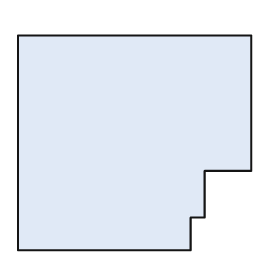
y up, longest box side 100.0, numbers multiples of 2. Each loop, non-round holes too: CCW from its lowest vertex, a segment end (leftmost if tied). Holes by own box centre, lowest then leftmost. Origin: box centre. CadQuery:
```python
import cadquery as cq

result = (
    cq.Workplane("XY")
    .moveTo(-50.0, -46.0)
    .lineTo(24.0, -46.0)
    .lineTo(24.0, -32.0)
    .lineTo(30.0, -32.0)
    .lineTo(30.0, -12.0)
    .lineTo(50.0, -12.0)
    .lineTo(50.0, 46.0)
    .lineTo(-50.0, 46.0)
    .close()
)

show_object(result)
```